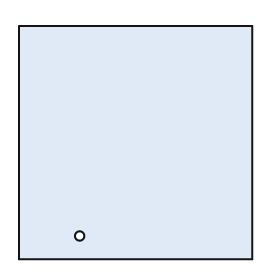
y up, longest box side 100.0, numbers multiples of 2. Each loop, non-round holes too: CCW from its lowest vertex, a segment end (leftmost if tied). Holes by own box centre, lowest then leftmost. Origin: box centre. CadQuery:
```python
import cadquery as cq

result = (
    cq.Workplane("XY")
    .moveTo(-50.0, -50.0)
    .lineTo(50.0, -50.0)
    .lineTo(50.0, 50.0)
    .lineTo(-50.0, 50.0)
    .close()
    .moveTo(-24.0, -40.0)
    .circle(2.0)
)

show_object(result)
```